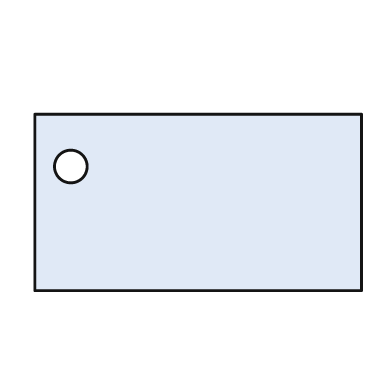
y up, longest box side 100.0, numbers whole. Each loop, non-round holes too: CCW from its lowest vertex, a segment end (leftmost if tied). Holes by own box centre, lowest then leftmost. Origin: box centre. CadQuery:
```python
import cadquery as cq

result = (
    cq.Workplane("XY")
    .moveTo(-50.0, -27.0)
    .lineTo(50.0, -27.0)
    .lineTo(50.0, 27.0)
    .lineTo(-50.0, 27.0)
    .close()
    .moveTo(-39.0, 11.0)
    .circle(5.0)
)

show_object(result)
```